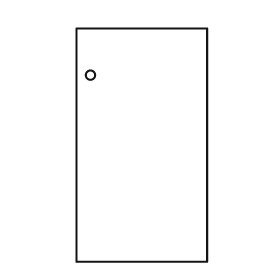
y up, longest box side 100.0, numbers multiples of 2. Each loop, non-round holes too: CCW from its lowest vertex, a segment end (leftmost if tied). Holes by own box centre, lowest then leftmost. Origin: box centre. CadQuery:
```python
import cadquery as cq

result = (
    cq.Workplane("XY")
    .moveTo(-28.0, -50.0)
    .lineTo(28.0, -50.0)
    .lineTo(28.0, 50.0)
    .lineTo(-28.0, 50.0)
    .close()
    .moveTo(-22.0, 30.0)
    .circle(2.0)
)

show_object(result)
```